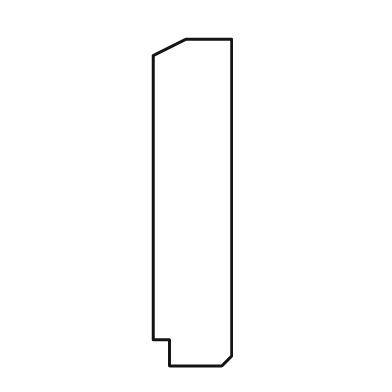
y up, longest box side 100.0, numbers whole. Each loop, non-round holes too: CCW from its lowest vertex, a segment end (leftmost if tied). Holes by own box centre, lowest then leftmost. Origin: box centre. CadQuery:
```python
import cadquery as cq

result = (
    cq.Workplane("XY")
    .moveTo(-7.0, -50.0)
    .lineTo(9.0, -50.0)
    .lineTo(12.0, -47.0)
    .lineTo(12.0, 50.0)
    .lineTo(-2.0, 50.0)
    .lineTo(-12.0, 45.0)
    .lineTo(-12.0, -42.0)
    .lineTo(-7.0, -42.0)
    .close()
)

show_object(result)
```